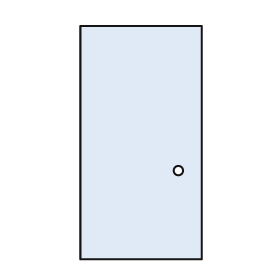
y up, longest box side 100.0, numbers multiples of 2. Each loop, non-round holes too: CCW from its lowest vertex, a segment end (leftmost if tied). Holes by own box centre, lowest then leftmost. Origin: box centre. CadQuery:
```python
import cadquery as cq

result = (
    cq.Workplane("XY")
    .moveTo(-26.0, -50.0)
    .lineTo(26.0, -50.0)
    .lineTo(26.0, 50.0)
    .lineTo(-26.0, 50.0)
    .close()
    .moveTo(16.0, -12.0)
    .circle(2.0)
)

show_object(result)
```